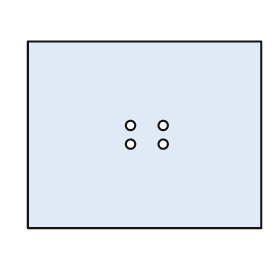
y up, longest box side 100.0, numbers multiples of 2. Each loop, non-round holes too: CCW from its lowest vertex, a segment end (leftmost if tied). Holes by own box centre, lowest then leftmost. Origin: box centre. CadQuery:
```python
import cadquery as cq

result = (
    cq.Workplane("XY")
    .moveTo(-50.0, -40.0)
    .lineTo(50.0, -40.0)
    .lineTo(50.0, 40.0)
    .lineTo(-50.0, 40.0)
    .close()
    .moveTo(-6.0, -4.0)
    .circle(2.0)
    .moveTo(8.0, -4.0)
    .circle(2.0)
    .moveTo(-6.0, 4.0)
    .circle(2.0)
    .moveTo(8.0, 4.0)
    .circle(2.0)
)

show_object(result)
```